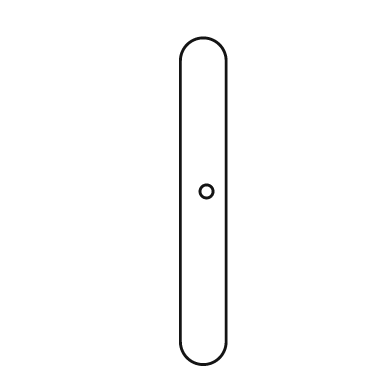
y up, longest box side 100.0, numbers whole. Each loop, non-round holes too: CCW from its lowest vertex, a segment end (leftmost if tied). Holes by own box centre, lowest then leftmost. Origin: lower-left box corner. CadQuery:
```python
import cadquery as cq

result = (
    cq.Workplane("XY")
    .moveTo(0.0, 7.0)
    .threePointArc((7.0, 0.0), (14.0, 7.0))
    .lineTo(14.0, 93.0)
    .threePointArc((7.0, 100.0), (0.0, 93.0))
    .close()
    .moveTo(8.0, 53.0)
    .circle(2.0)
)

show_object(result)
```